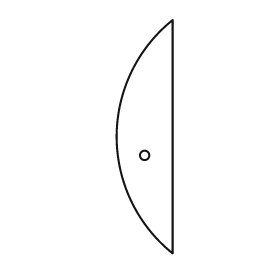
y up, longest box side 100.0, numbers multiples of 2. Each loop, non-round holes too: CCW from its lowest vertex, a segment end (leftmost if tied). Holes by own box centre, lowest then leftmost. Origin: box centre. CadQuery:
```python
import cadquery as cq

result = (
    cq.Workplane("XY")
    .moveTo(12.0, -50.0)
    .lineTo(12.0, 50.0)
    .threePointArc((-12.0, 0.0), (12.0, -50.0))
    .close()
    .moveTo(0.0, -8.0)
    .circle(2.0)
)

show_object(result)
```